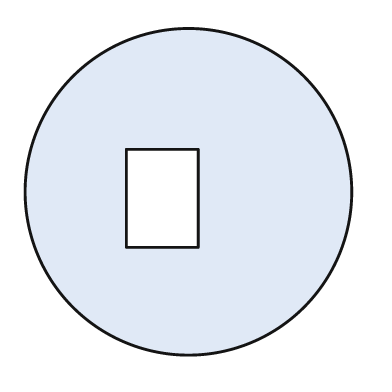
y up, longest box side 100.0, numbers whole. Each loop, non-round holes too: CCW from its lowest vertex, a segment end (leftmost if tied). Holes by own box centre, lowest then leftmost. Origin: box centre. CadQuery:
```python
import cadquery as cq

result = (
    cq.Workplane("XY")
    .moveTo(0.0, 0.0)
    .circle(50.0)
    .moveTo(-19.0, -17.0)
    .lineTo(3.0, -17.0)
    .lineTo(3.0, 13.0)
    .lineTo(-19.0, 13.0)
    .close()
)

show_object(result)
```